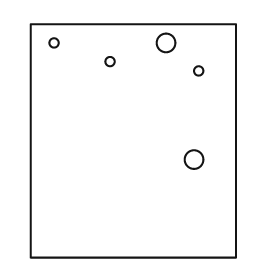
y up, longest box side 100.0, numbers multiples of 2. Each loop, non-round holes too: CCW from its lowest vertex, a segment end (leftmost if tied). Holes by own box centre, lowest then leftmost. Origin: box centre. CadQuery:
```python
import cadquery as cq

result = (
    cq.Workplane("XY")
    .moveTo(-44.0, -50.0)
    .lineTo(44.0, -50.0)
    .lineTo(44.0, 50.0)
    .lineTo(-44.0, 50.0)
    .close()
    .moveTo(26.0, -8.0)
    .circle(4.0)
    .moveTo(28.0, 30.0)
    .circle(2.0)
    .moveTo(-10.0, 34.0)
    .circle(2.0)
    .moveTo(-34.0, 42.0)
    .circle(2.0)
    .moveTo(14.0, 42.0)
    .circle(4.0)
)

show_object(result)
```